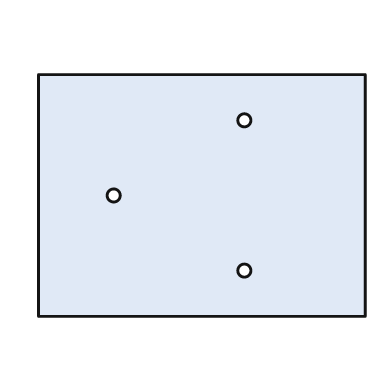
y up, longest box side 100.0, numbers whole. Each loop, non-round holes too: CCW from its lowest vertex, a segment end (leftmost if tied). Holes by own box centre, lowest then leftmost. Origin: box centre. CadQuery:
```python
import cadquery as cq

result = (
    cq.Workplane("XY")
    .moveTo(-50.0, -37.0)
    .lineTo(50.0, -37.0)
    .lineTo(50.0, 37.0)
    .lineTo(-50.0, 37.0)
    .close()
    .moveTo(13.0, -23.0)
    .circle(2.0)
    .moveTo(-27.0, 0.0)
    .circle(2.0)
    .moveTo(13.0, 23.0)
    .circle(2.0)
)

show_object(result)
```